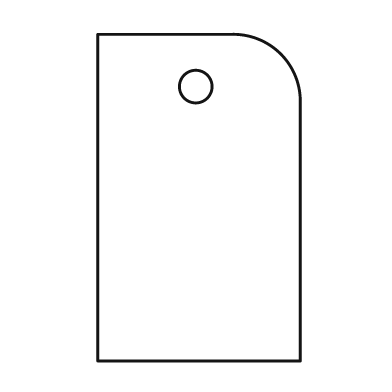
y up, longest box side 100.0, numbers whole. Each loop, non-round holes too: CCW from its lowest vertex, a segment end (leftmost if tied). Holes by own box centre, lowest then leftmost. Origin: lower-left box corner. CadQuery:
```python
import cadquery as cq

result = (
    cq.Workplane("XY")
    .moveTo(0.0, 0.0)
    .lineTo(62.0, 0.0)
    .lineTo(62.0, 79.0)
    .threePointArc((56.0, 94.0), (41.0, 100.0))
    .lineTo(0.0, 100.0)
    .close()
    .moveTo(30.0, 84.0)
    .circle(5.0)
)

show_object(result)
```